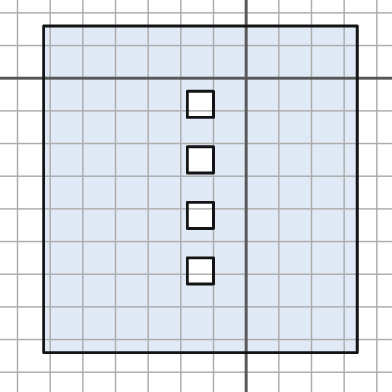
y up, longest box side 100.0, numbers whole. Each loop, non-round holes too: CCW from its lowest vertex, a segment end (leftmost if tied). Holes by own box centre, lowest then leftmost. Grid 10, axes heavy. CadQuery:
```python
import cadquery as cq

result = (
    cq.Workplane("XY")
    .moveTo(-62.0, -84.0)
    .lineTo(34.0, -84.0)
    .lineTo(34.0, 16.0)
    .lineTo(-62.0, 16.0)
    .close()
    .moveTo(-18.0, -63.0)
    .lineTo(-10.0, -63.0)
    .lineTo(-10.0, -55.0)
    .lineTo(-18.0, -55.0)
    .close()
    .moveTo(-18.0, -46.0)
    .lineTo(-10.0, -46.0)
    .lineTo(-10.0, -38.0)
    .lineTo(-18.0, -38.0)
    .close()
    .moveTo(-18.0, -29.0)
    .lineTo(-10.0, -29.0)
    .lineTo(-10.0, -21.0)
    .lineTo(-18.0, -21.0)
    .close()
    .moveTo(-18.0, -12.0)
    .lineTo(-10.0, -12.0)
    .lineTo(-10.0, -4.0)
    .lineTo(-18.0, -4.0)
    .close()
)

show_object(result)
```